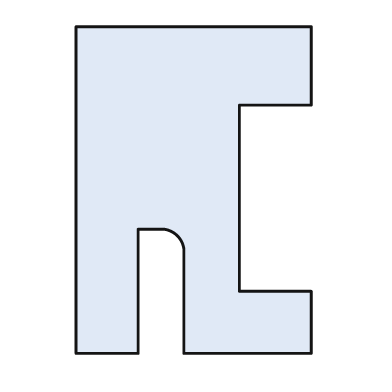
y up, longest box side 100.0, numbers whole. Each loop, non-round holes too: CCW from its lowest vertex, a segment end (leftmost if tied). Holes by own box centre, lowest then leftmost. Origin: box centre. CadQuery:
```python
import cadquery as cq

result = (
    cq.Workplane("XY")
    .moveTo(-36.0, -50.0)
    .lineTo(-17.0, -50.0)
    .lineTo(-17.0, -12.0)
    .lineTo(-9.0, -12.0)
    .threePointArc((-5.0, -14.0), (-3.0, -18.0))
    .lineTo(-3.0, -50.0)
    .lineTo(36.0, -50.0)
    .lineTo(36.0, -31.0)
    .lineTo(14.0, -31.0)
    .lineTo(14.0, 26.0)
    .lineTo(36.0, 26.0)
    .lineTo(36.0, 50.0)
    .lineTo(-36.0, 50.0)
    .close()
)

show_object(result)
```